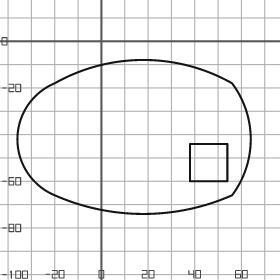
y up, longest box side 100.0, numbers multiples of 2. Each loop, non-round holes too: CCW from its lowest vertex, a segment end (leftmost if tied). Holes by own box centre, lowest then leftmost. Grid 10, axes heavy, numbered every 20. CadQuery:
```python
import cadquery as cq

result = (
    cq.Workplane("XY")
    .moveTo(-20.0, -66.0)
    .threePointArc((18.0, -74.0), (56.0, -66.0))
    .threePointArc((64.0, -42.0), (56.0, -18.0))
    .threePointArc((18.0, -8.0), (-20.0, -18.0))
    .threePointArc((-36.0, -42.0), (-20.0, -66.0))
    .close()
    .moveTo(38.0, -60.0)
    .lineTo(54.0, -60.0)
    .lineTo(54.0, -44.0)
    .lineTo(38.0, -44.0)
    .close()
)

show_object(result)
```